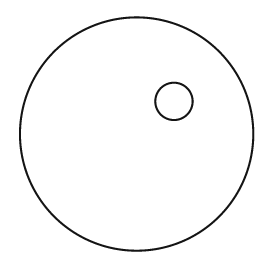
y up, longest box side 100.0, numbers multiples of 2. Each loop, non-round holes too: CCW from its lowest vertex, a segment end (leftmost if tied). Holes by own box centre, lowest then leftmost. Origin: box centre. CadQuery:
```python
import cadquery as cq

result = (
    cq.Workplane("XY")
    .moveTo(0.0, 0.0)
    .circle(50.0)
    .moveTo(16.0, 14.0)
    .circle(8.0)
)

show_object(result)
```